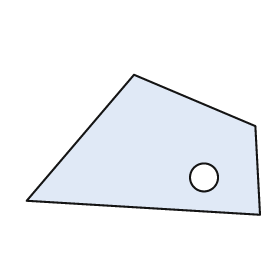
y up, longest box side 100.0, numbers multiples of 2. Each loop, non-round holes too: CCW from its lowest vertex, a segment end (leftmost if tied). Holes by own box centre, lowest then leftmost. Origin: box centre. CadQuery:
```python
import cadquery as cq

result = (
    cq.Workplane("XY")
    .moveTo(50.0, -30.0)
    .lineTo(48.0, 8.0)
    .lineTo(-4.0, 30.0)
    .lineTo(-50.0, -24.0)
    .close()
    .moveTo(26.0, -14.0)
    .circle(6.0)
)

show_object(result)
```